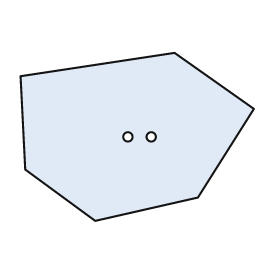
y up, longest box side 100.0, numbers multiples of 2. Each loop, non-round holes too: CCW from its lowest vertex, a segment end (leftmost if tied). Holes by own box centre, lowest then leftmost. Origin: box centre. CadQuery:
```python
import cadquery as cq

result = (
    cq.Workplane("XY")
    .moveTo(-18.0, -36.0)
    .lineTo(26.0, -26.0)
    .lineTo(50.0, 12.0)
    .lineTo(16.0, 36.0)
    .lineTo(-50.0, 26.0)
    .lineTo(-48.0, -14.0)
    .close()
    .moveTo(-4.0, 0.0)
    .circle(2.0)
    .moveTo(6.0, 0.0)
    .circle(2.0)
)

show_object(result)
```